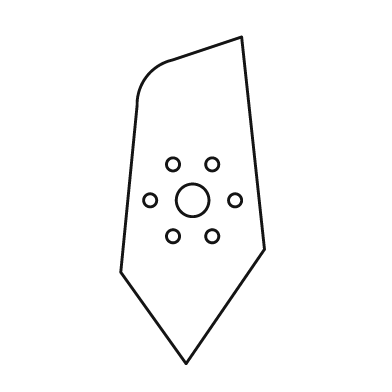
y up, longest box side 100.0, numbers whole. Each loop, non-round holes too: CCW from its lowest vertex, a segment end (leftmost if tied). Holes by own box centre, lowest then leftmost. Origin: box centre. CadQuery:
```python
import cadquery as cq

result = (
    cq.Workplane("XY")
    .moveTo(-2.0, -50.0)
    .lineTo(22.0, -15.0)
    .lineTo(15.0, 50.0)
    .lineTo(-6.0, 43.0)
    .threePointArc((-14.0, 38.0), (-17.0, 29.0))
    .lineTo(-22.0, -22.0)
    .close()
    .moveTo(-6.0, -11.0)
    .circle(2.0)
    .moveTo(6.0, -11.0)
    .circle(2.0)
    .moveTo(-13.0, 0.0)
    .circle(2.0)
    .moveTo(0.0, 0.0)
    .circle(5.0)
    .moveTo(13.0, 0.0)
    .circle(2.0)
    .moveTo(-6.0, 11.0)
    .circle(2.0)
    .moveTo(6.0, 11.0)
    .circle(2.0)
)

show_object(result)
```